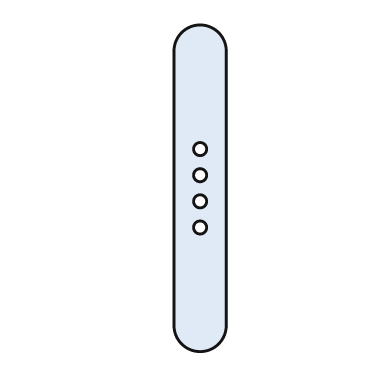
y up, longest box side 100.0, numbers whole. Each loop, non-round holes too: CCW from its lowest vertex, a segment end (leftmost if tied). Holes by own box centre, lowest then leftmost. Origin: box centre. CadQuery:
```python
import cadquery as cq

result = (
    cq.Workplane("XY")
    .moveTo(-8.0, -42.0)
    .threePointArc((0.0, -50.0), (8.0, -42.0))
    .lineTo(8.0, 42.0)
    .threePointArc((0.0, 50.0), (-8.0, 42.0))
    .close()
    .moveTo(0.0, -12.0)
    .circle(2.0)
    .moveTo(0.0, -4.0)
    .circle(2.0)
    .moveTo(0.0, 4.0)
    .circle(2.0)
    .moveTo(0.0, 12.0)
    .circle(2.0)
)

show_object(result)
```